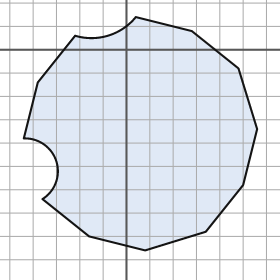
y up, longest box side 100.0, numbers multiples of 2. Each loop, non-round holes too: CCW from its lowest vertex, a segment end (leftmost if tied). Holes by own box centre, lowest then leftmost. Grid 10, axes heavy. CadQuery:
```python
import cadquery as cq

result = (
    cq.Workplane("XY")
    .moveTo(8.0, -86.0)
    .lineTo(34.0, -78.0)
    .lineTo(50.0, -58.0)
    .lineTo(56.0, -34.0)
    .lineTo(48.0, -8.0)
    .lineTo(28.0, 8.0)
    .lineTo(4.0, 14.0)
    .threePointArc((-8.0, 6.0), (-22.0, 6.0))
    .lineTo(-38.0, -14.0)
    .lineTo(-44.0, -38.0)
    .threePointArc((-30.0, -48.0), (-36.0, -64.0))
    .lineTo(-16.0, -80.0)
    .close()
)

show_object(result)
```